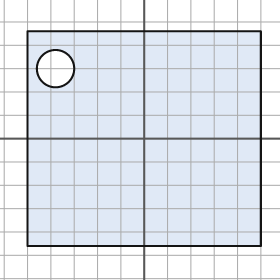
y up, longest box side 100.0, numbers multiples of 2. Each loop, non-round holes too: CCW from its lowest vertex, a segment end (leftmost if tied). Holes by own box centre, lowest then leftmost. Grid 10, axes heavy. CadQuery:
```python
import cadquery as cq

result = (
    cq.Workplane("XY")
    .moveTo(-50.0, -46.0)
    .lineTo(50.0, -46.0)
    .lineTo(50.0, 46.0)
    .lineTo(-50.0, 46.0)
    .close()
    .moveTo(-38.0, 30.0)
    .circle(8.0)
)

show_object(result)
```